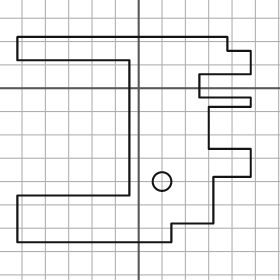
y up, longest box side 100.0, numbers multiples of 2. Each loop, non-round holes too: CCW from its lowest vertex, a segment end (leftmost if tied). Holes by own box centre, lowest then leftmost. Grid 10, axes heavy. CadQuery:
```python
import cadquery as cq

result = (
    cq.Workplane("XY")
    .moveTo(-52.0, -66.0)
    .lineTo(14.0, -66.0)
    .lineTo(14.0, -58.0)
    .lineTo(32.0, -58.0)
    .lineTo(32.0, -38.0)
    .lineTo(48.0, -38.0)
    .lineTo(48.0, -26.0)
    .lineTo(30.0, -26.0)
    .lineTo(30.0, -8.0)
    .lineTo(48.0, -8.0)
    .lineTo(48.0, -4.0)
    .lineTo(26.0, -4.0)
    .lineTo(26.0, 6.0)
    .lineTo(48.0, 6.0)
    .lineTo(48.0, 16.0)
    .lineTo(38.0, 16.0)
    .lineTo(38.0, 22.0)
    .lineTo(-52.0, 22.0)
    .lineTo(-52.0, 12.0)
    .lineTo(-4.0, 12.0)
    .lineTo(-4.0, -46.0)
    .lineTo(-52.0, -46.0)
    .close()
    .moveTo(10.0, -40.0)
    .circle(4.0)
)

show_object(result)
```